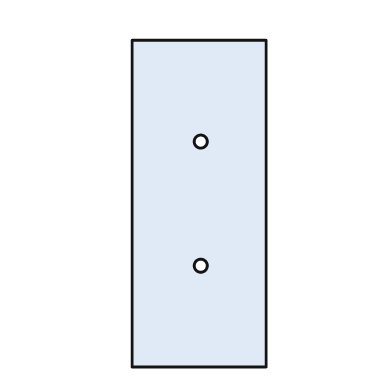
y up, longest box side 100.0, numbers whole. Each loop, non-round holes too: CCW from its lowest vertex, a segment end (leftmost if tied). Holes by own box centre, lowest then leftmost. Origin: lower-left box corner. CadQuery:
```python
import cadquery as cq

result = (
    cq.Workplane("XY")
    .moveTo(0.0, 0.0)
    .lineTo(41.0, 0.0)
    .lineTo(41.0, 100.0)
    .lineTo(0.0, 100.0)
    .close()
    .moveTo(21.0, 31.0)
    .circle(2.0)
    .moveTo(21.0, 69.0)
    .circle(2.0)
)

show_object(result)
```